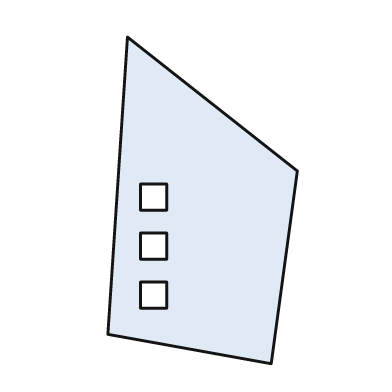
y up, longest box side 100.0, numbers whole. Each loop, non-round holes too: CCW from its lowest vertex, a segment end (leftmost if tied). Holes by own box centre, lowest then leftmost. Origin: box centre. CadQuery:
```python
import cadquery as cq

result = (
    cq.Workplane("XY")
    .moveTo(21.0, -50.0)
    .lineTo(29.0, 9.0)
    .lineTo(-23.0, 50.0)
    .lineTo(-29.0, -41.0)
    .close()
    .moveTo(-19.0, -33.0)
    .lineTo(-11.0, -33.0)
    .lineTo(-11.0, -25.0)
    .lineTo(-19.0, -25.0)
    .close()
    .moveTo(-19.0, -18.0)
    .lineTo(-11.0, -18.0)
    .lineTo(-11.0, -10.0)
    .lineTo(-19.0, -10.0)
    .close()
    .moveTo(-19.0, -3.0)
    .lineTo(-11.0, -3.0)
    .lineTo(-11.0, 5.0)
    .lineTo(-19.0, 5.0)
    .close()
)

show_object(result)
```